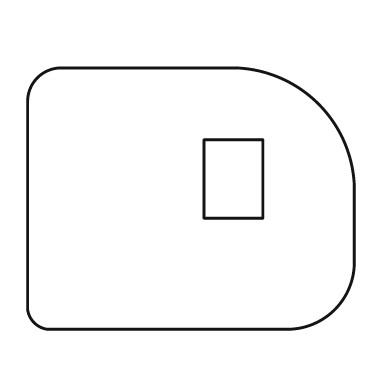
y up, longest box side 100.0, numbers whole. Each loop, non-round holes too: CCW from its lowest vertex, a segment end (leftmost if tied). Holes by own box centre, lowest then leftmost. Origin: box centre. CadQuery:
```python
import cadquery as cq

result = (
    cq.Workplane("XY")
    .moveTo(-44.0, -40.0)
    .lineTo(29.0, -40.0)
    .threePointArc((44.0, -34.0), (50.0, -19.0))
    .lineTo(50.0, 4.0)
    .threePointArc((39.0, 29.0), (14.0, 40.0))
    .lineTo(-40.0, 40.0)
    .threePointArc((-47.0, 37.0), (-50.0, 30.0))
    .lineTo(-50.0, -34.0)
    .threePointArc((-48.0, -38.0), (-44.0, -40.0))
    .close()
    .moveTo(4.0, -6.0)
    .lineTo(22.0, -6.0)
    .lineTo(22.0, 18.0)
    .lineTo(4.0, 18.0)
    .close()
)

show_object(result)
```